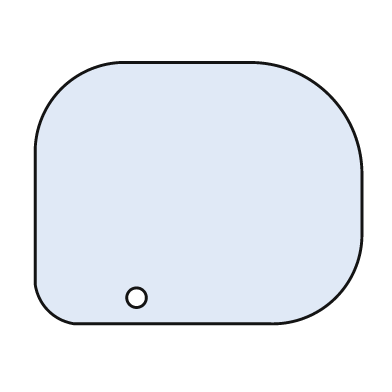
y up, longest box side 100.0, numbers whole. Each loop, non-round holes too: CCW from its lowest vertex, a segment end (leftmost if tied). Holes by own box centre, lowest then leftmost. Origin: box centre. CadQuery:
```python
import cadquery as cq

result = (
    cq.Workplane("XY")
    .moveTo(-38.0, -40.0)
    .lineTo(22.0, -40.0)
    .threePointArc((42.0, -32.0), (50.0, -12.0))
    .lineTo(50.0, 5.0)
    .threePointArc((40.0, 30.0), (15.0, 40.0))
    .lineTo(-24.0, 40.0)
    .threePointArc((-42.0, 32.0), (-50.0, 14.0))
    .lineTo(-50.0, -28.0)
    .threePointArc((-46.0, -36.0), (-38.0, -40.0))
    .close()
    .moveTo(-19.0, -32.0)
    .circle(3.0)
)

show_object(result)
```